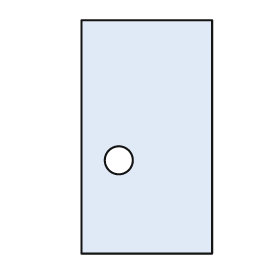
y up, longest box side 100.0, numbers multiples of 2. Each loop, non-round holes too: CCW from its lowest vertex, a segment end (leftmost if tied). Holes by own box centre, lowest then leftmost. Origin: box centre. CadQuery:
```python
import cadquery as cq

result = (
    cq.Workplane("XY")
    .moveTo(-28.0, -50.0)
    .lineTo(28.0, -50.0)
    .lineTo(28.0, 50.0)
    .lineTo(-28.0, 50.0)
    .close()
    .moveTo(-12.0, -10.0)
    .circle(6.0)
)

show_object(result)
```